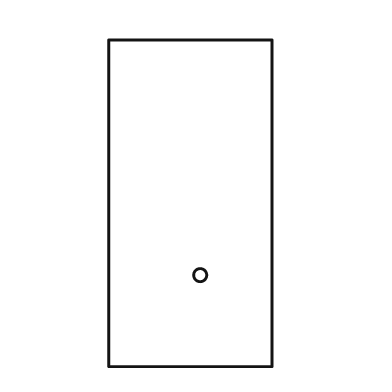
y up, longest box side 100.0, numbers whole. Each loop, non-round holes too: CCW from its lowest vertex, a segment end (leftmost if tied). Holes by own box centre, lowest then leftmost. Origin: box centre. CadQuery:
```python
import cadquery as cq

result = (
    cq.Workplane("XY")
    .moveTo(-25.0, -50.0)
    .lineTo(25.0, -50.0)
    .lineTo(25.0, 50.0)
    .lineTo(-25.0, 50.0)
    .close()
    .moveTo(3.0, -22.0)
    .circle(2.0)
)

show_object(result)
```